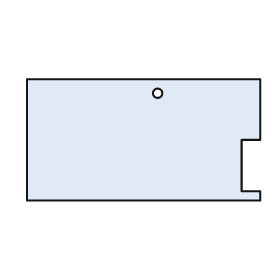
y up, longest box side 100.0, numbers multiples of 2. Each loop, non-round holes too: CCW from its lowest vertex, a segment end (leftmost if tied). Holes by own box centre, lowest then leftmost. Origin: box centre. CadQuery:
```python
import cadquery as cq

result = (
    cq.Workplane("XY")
    .moveTo(-50.0, -26.0)
    .lineTo(50.0, -26.0)
    .lineTo(50.0, -22.0)
    .lineTo(42.0, -22.0)
    .lineTo(42.0, 0.0)
    .lineTo(50.0, 0.0)
    .lineTo(50.0, 26.0)
    .lineTo(-50.0, 26.0)
    .close()
    .moveTo(6.0, 20.0)
    .circle(2.0)
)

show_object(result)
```